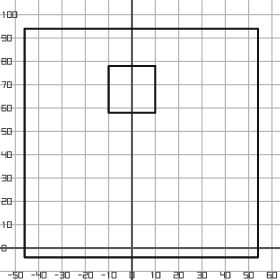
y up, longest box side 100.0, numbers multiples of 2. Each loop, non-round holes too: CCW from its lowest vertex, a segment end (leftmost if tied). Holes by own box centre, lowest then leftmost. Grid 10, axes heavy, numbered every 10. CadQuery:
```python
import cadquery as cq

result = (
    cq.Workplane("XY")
    .moveTo(-46.0, -4.0)
    .lineTo(54.0, -4.0)
    .lineTo(54.0, 94.0)
    .lineTo(-46.0, 94.0)
    .close()
    .moveTo(-10.0, 58.0)
    .lineTo(10.0, 58.0)
    .lineTo(10.0, 78.0)
    .lineTo(-10.0, 78.0)
    .close()
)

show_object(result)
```